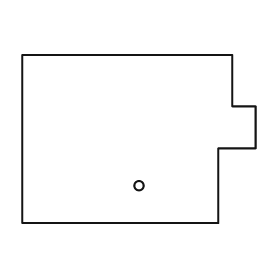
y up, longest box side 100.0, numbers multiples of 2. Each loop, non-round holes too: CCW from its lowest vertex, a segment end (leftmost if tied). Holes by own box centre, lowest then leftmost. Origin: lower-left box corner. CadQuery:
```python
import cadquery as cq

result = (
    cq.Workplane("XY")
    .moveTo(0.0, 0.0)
    .lineTo(84.0, 0.0)
    .lineTo(84.0, 32.0)
    .lineTo(100.0, 32.0)
    .lineTo(100.0, 50.0)
    .lineTo(90.0, 50.0)
    .lineTo(90.0, 72.0)
    .lineTo(0.0, 72.0)
    .close()
    .moveTo(50.0, 16.0)
    .circle(2.0)
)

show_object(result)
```